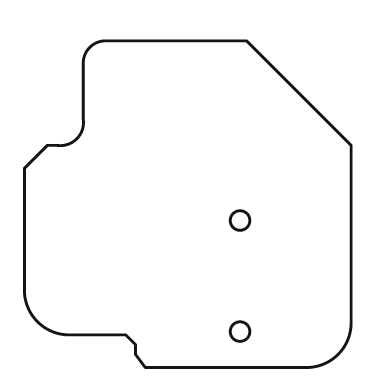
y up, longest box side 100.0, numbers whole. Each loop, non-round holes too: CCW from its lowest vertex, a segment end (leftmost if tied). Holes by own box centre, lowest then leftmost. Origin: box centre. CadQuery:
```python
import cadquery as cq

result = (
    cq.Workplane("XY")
    .moveTo(-13.0, -50.0)
    .lineTo(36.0, -50.0)
    .threePointArc((46.0, -46.0), (50.0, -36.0))
    .lineTo(50.0, 18.0)
    .lineTo(18.0, 50.0)
    .lineTo(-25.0, 50.0)
    .threePointArc((-30.0, 48.0), (-32.0, 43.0))
    .lineTo(-32.0, 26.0)
    .threePointArc((-34.0, 20.0), (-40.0, 18.0))
    .lineTo(-43.0, 18.0)
    .lineTo(-50.0, 11.0)
    .lineTo(-50.0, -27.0)
    .threePointArc((-46.0, -36.0), (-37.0, -40.0))
    .lineTo(-19.0, -40.0)
    .lineTo(-16.0, -43.0)
    .lineTo(-16.0, -46.0)
    .close()
    .moveTo(16.0, -39.0)
    .circle(3.0)
    .moveTo(16.0, -5.0)
    .circle(3.0)
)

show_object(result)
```